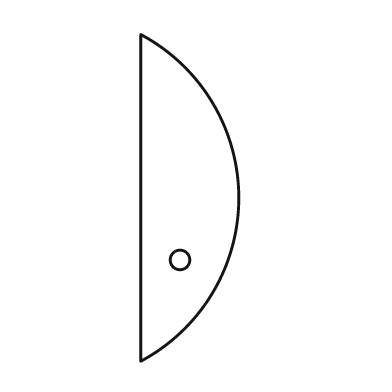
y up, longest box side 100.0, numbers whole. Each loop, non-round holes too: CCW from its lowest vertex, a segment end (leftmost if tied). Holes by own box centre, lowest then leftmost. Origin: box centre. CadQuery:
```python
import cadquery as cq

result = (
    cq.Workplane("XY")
    .moveTo(-15.0, -50.0)
    .threePointArc((15.0, 0.0), (-15.0, 50.0))
    .close()
    .moveTo(-3.0, -19.0)
    .circle(3.0)
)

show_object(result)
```